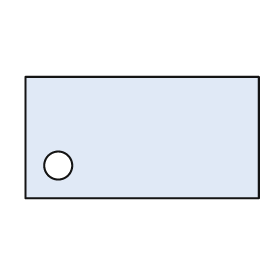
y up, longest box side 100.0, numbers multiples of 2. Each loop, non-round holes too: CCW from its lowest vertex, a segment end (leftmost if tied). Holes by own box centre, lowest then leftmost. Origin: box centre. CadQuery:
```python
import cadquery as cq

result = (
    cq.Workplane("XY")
    .moveTo(-50.0, -26.0)
    .lineTo(50.0, -26.0)
    .lineTo(50.0, 26.0)
    .lineTo(-50.0, 26.0)
    .close()
    .moveTo(-36.0, -12.0)
    .circle(6.0)
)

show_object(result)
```